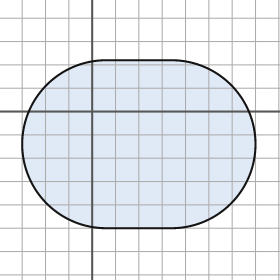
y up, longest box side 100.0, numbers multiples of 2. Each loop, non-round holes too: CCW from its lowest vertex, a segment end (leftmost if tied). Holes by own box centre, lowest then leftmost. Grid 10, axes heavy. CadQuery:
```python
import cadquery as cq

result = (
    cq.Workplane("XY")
    .moveTo(6.0, -50.0)
    .lineTo(34.0, -50.0)
    .threePointArc((70.0, -14.0), (34.0, 22.0))
    .lineTo(6.0, 22.0)
    .threePointArc((-30.0, -14.0), (6.0, -50.0))
    .close()
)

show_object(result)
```